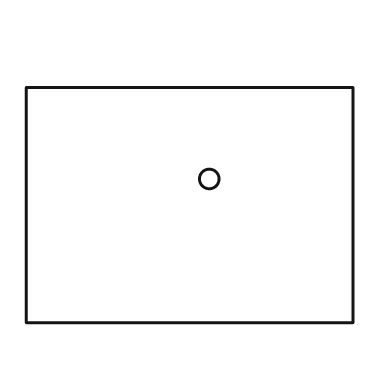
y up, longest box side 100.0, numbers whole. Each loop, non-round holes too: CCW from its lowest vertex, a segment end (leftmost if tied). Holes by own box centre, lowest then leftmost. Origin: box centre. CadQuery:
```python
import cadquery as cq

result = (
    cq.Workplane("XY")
    .moveTo(-50.0, -36.0)
    .lineTo(50.0, -36.0)
    .lineTo(50.0, 36.0)
    .lineTo(-50.0, 36.0)
    .close()
    .moveTo(6.0, 8.0)
    .circle(3.0)
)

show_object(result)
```